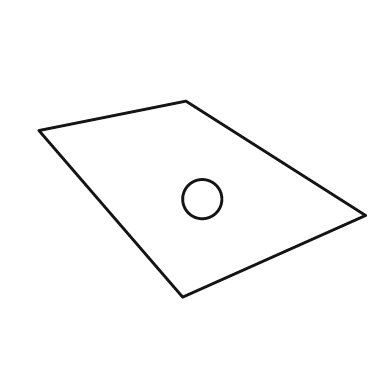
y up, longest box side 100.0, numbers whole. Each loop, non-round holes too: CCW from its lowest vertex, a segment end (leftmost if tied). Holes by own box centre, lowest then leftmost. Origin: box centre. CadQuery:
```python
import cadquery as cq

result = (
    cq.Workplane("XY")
    .moveTo(-6.0, -30.0)
    .lineTo(50.0, -5.0)
    .lineTo(-5.0, 30.0)
    .lineTo(-50.0, 21.0)
    .close()
    .moveTo(0.0, 0.0)
    .circle(6.0)
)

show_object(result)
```